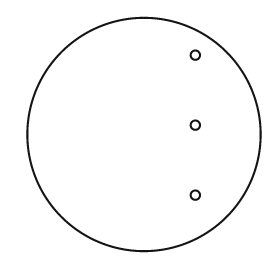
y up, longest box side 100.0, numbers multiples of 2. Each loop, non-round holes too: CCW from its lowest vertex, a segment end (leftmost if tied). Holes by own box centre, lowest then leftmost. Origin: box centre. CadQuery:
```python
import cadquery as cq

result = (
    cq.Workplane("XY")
    .moveTo(0.0, 0.0)
    .circle(50.0)
    .moveTo(22.0, -26.0)
    .circle(2.0)
    .moveTo(22.0, 4.0)
    .circle(2.0)
    .moveTo(22.0, 34.0)
    .circle(2.0)
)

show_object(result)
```